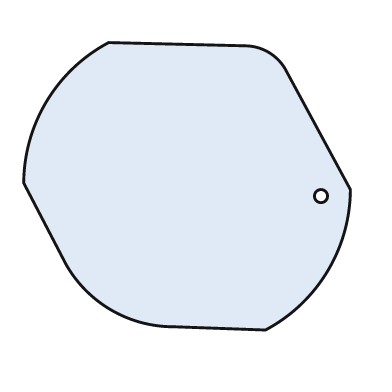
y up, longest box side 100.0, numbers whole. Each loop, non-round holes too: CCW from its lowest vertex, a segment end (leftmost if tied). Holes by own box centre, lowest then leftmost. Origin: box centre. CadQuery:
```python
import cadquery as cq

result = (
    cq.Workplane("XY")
    .moveTo(24.0, -44.0)
    .threePointArc((43.0, -26.0), (50.0, -1.0))
    .lineTo(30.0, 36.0)
    .threePointArc((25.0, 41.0), (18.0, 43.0))
    .lineTo(-24.0, 44.0)
    .threePointArc((-43.0, 26.0), (-50.0, 1.0))
    .lineTo(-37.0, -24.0)
    .threePointArc((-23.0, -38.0), (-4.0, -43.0))
    .close()
    .moveTo(41.0, -3.0)
    .circle(2.0)
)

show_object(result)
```